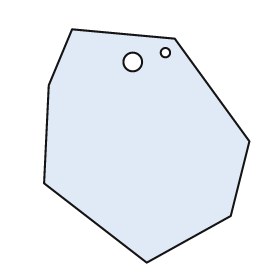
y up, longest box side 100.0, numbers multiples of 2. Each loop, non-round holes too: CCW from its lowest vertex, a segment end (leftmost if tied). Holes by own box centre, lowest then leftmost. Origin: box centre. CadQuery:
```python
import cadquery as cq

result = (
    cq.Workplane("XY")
    .moveTo(0.0, -50.0)
    .lineTo(36.0, -30.0)
    .lineTo(44.0, 2.0)
    .lineTo(12.0, 46.0)
    .lineTo(-32.0, 50.0)
    .lineTo(-42.0, 26.0)
    .lineTo(-44.0, -16.0)
    .close()
    .moveTo(-6.0, 36.0)
    .circle(4.0)
    .moveTo(8.0, 40.0)
    .circle(2.0)
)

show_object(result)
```